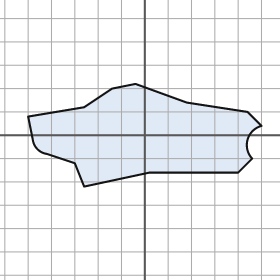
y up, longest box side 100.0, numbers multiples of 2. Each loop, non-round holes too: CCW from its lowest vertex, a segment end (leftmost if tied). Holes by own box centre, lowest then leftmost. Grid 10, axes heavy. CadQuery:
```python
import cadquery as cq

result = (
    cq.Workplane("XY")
    .moveTo(-26.0, -22.0)
    .lineTo(2.0, -16.0)
    .lineTo(40.0, -16.0)
    .lineTo(46.0, -10.0)
    .threePointArc((44.0, -2.0), (50.0, 4.0))
    .lineTo(44.0, 10.0)
    .lineTo(18.0, 14.0)
    .lineTo(-4.0, 22.0)
    .lineTo(-14.0, 20.0)
    .lineTo(-26.0, 12.0)
    .lineTo(-50.0, 8.0)
    .lineTo(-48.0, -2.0)
    .threePointArc((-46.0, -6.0), (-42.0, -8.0))
    .lineTo(-30.0, -12.0)
    .close()
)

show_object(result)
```